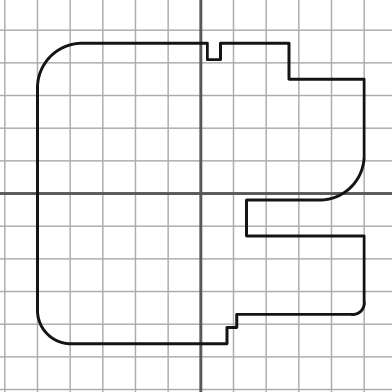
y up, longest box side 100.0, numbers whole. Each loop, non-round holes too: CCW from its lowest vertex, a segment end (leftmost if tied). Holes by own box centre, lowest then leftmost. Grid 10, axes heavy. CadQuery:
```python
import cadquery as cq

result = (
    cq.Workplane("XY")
    .moveTo(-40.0, -46.0)
    .lineTo(8.0, -46.0)
    .lineTo(8.0, -41.0)
    .lineTo(11.0, -41.0)
    .lineTo(11.0, -37.0)
    .lineTo(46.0, -37.0)
    .threePointArc((49.0, -36.0), (50.0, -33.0))
    .lineTo(50.0, -13.0)
    .lineTo(14.0, -13.0)
    .lineTo(14.0, -2.0)
    .lineTo(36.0, -2.0)
    .threePointArc((46.0, 2.0), (50.0, 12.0))
    .lineTo(50.0, 35.0)
    .lineTo(27.0, 35.0)
    .lineTo(27.0, 46.0)
    .lineTo(6.0, 46.0)
    .lineTo(6.0, 41.0)
    .lineTo(2.0, 41.0)
    .lineTo(2.0, 46.0)
    .lineTo(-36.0, 46.0)
    .threePointArc((-46.0, 42.0), (-50.0, 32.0))
    .lineTo(-50.0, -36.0)
    .threePointArc((-47.0, -43.0), (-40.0, -46.0))
    .close()
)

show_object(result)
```